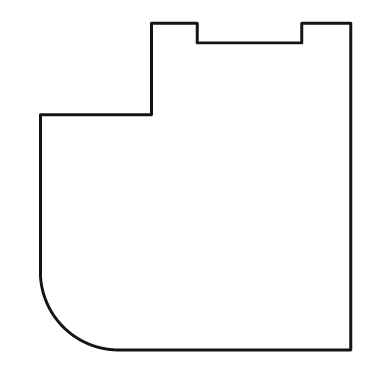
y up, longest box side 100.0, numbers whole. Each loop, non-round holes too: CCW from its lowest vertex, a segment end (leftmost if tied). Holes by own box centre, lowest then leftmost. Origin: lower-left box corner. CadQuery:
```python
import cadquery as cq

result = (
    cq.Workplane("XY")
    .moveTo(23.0, 0.0)
    .lineTo(95.0, 0.0)
    .lineTo(95.0, 100.0)
    .lineTo(80.0, 100.0)
    .lineTo(80.0, 94.0)
    .lineTo(48.0, 94.0)
    .lineTo(48.0, 100.0)
    .lineTo(34.0, 100.0)
    .lineTo(34.0, 72.0)
    .lineTo(0.0, 72.0)
    .lineTo(0.0, 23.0)
    .threePointArc((7.0, 7.0), (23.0, 0.0))
    .close()
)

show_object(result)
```